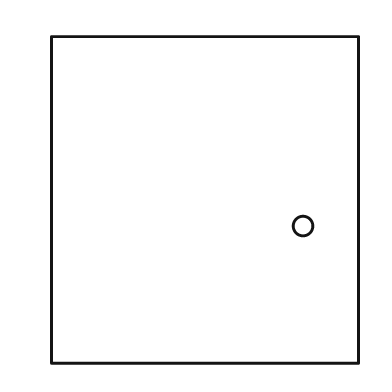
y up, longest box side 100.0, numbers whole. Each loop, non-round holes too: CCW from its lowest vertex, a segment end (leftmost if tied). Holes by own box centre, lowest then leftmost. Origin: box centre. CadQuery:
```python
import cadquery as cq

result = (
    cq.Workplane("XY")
    .moveTo(-47.0, -50.0)
    .lineTo(47.0, -50.0)
    .lineTo(47.0, 50.0)
    .lineTo(-47.0, 50.0)
    .close()
    .moveTo(30.0, -8.0)
    .circle(3.0)
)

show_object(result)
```